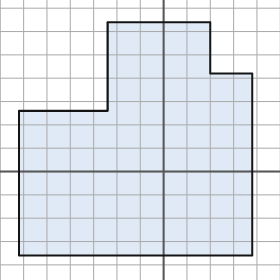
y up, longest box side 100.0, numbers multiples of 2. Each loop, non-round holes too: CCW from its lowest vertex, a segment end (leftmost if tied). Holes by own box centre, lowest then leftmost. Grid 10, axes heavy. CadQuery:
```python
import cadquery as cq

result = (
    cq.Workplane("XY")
    .moveTo(-62.0, -36.0)
    .lineTo(38.0, -36.0)
    .lineTo(38.0, 42.0)
    .lineTo(20.0, 42.0)
    .lineTo(20.0, 64.0)
    .lineTo(-24.0, 64.0)
    .lineTo(-24.0, 26.0)
    .lineTo(-62.0, 26.0)
    .close()
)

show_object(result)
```